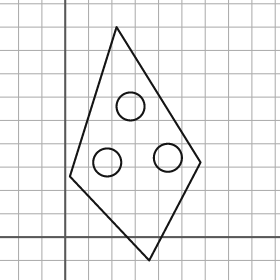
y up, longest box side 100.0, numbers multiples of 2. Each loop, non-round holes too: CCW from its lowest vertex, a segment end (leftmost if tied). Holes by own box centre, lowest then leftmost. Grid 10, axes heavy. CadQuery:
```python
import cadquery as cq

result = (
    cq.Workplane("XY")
    .moveTo(36.0, -10.0)
    .lineTo(58.0, 32.0)
    .lineTo(22.0, 90.0)
    .lineTo(2.0, 26.0)
    .close()
    .moveTo(18.0, 32.0)
    .circle(6.0)
    .moveTo(44.0, 34.0)
    .circle(6.0)
    .moveTo(28.0, 56.0)
    .circle(6.0)
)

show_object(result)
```